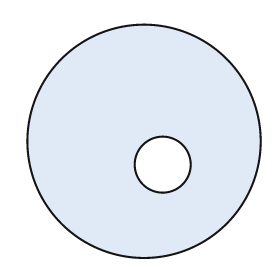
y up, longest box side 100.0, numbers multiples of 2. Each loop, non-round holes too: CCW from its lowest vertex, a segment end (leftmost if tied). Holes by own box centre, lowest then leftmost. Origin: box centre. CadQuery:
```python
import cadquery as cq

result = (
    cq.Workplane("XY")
    .moveTo(0.0, 0.0)
    .circle(50.0)
    .moveTo(8.0, -10.0)
    .circle(12.0)
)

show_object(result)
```